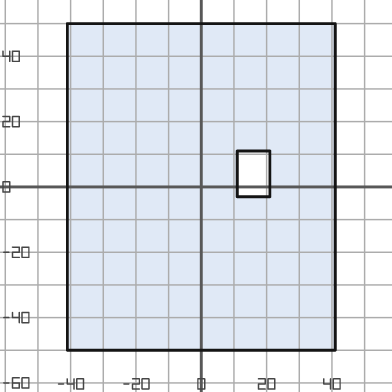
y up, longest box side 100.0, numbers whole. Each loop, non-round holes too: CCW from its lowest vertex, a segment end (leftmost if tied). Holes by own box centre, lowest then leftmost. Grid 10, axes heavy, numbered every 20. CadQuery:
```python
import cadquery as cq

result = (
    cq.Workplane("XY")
    .moveTo(-41.0, -50.0)
    .lineTo(41.0, -50.0)
    .lineTo(41.0, 50.0)
    .lineTo(-41.0, 50.0)
    .close()
    .moveTo(11.0, -3.0)
    .lineTo(21.0, -3.0)
    .lineTo(21.0, 11.0)
    .lineTo(11.0, 11.0)
    .close()
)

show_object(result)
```